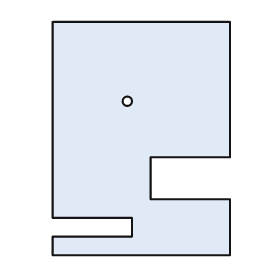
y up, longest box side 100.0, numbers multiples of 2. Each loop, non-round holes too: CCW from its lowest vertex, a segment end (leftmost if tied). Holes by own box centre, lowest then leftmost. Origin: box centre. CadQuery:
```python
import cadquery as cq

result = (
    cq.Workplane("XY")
    .moveTo(-38.0, -50.0)
    .lineTo(38.0, -50.0)
    .lineTo(38.0, -26.0)
    .lineTo(4.0, -26.0)
    .lineTo(4.0, -8.0)
    .lineTo(38.0, -8.0)
    .lineTo(38.0, 50.0)
    .lineTo(-38.0, 50.0)
    .lineTo(-38.0, -34.0)
    .lineTo(-4.0, -34.0)
    .lineTo(-4.0, -42.0)
    .lineTo(-38.0, -42.0)
    .close()
    .moveTo(-6.0, 16.0)
    .circle(2.0)
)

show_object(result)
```